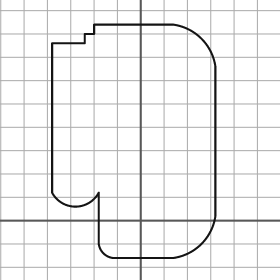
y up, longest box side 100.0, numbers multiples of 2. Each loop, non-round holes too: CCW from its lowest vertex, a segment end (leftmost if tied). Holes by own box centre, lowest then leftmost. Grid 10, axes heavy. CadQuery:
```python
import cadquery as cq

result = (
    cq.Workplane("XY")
    .moveTo(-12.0, -16.0)
    .lineTo(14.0, -16.0)
    .threePointArc((26.0, -10.0), (32.0, 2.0))
    .lineTo(32.0, 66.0)
    .threePointArc((26.0, 78.0), (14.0, 84.0))
    .lineTo(-20.0, 84.0)
    .lineTo(-20.0, 80.0)
    .lineTo(-24.0, 80.0)
    .lineTo(-24.0, 76.0)
    .lineTo(-38.0, 76.0)
    .lineTo(-38.0, 12.0)
    .threePointArc((-28.0, 6.0), (-18.0, 12.0))
    .lineTo(-18.0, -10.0)
    .threePointArc((-16.0, -14.0), (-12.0, -16.0))
    .close()
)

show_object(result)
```